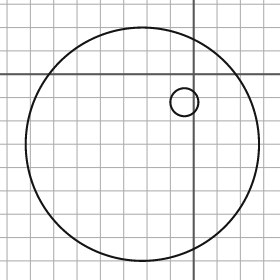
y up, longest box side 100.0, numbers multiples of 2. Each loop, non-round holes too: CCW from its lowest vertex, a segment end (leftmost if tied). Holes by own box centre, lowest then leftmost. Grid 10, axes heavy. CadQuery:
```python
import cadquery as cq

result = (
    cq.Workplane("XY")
    .moveTo(-22.0, -30.0)
    .circle(50.0)
    .moveTo(-4.0, -12.0)
    .circle(6.0)
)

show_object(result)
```